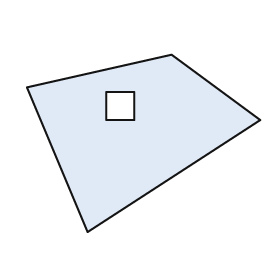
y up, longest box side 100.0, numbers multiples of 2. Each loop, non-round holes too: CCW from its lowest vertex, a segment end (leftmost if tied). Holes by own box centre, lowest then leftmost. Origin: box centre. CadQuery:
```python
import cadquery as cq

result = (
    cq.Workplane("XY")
    .moveTo(-24.0, -38.0)
    .lineTo(50.0, 10.0)
    .lineTo(12.0, 38.0)
    .lineTo(-50.0, 24.0)
    .close()
    .moveTo(-16.0, 10.0)
    .lineTo(-4.0, 10.0)
    .lineTo(-4.0, 22.0)
    .lineTo(-16.0, 22.0)
    .close()
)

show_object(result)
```